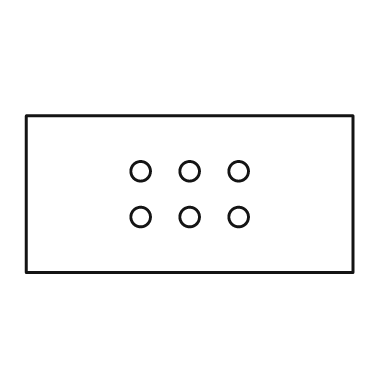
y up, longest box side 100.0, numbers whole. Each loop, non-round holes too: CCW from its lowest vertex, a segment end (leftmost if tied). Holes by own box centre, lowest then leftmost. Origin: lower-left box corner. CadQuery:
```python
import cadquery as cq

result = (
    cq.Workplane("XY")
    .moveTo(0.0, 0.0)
    .lineTo(100.0, 0.0)
    .lineTo(100.0, 48.0)
    .lineTo(0.0, 48.0)
    .close()
    .moveTo(35.0, 17.0)
    .circle(3.0)
    .moveTo(50.0, 17.0)
    .circle(3.0)
    .moveTo(65.0, 17.0)
    .circle(3.0)
    .moveTo(35.0, 31.0)
    .circle(3.0)
    .moveTo(50.0, 31.0)
    .circle(3.0)
    .moveTo(65.0, 31.0)
    .circle(3.0)
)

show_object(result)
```